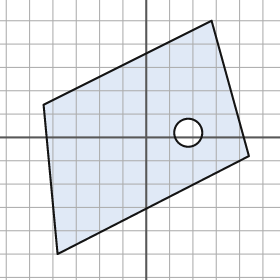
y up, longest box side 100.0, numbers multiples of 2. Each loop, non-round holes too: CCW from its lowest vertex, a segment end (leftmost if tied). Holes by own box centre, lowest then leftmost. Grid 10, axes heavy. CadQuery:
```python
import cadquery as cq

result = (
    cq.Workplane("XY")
    .moveTo(-38.0, -50.0)
    .lineTo(44.0, -8.0)
    .lineTo(28.0, 50.0)
    .lineTo(-44.0, 14.0)
    .close()
    .moveTo(18.0, 2.0)
    .circle(6.0)
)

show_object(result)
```